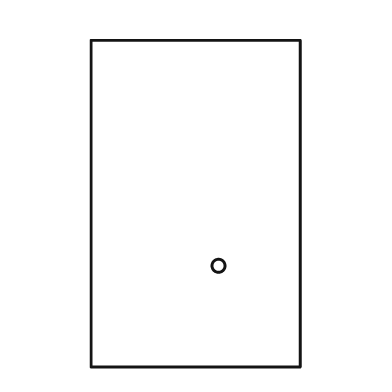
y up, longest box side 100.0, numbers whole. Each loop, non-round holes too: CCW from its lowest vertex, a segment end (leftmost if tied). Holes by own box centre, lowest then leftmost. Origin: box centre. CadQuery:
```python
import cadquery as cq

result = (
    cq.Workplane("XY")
    .moveTo(-32.0, -50.0)
    .lineTo(32.0, -50.0)
    .lineTo(32.0, 50.0)
    .lineTo(-32.0, 50.0)
    .close()
    .moveTo(7.0, -19.0)
    .circle(2.0)
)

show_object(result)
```